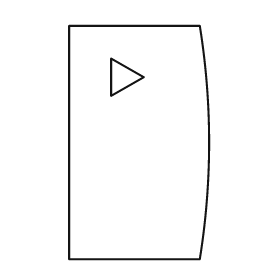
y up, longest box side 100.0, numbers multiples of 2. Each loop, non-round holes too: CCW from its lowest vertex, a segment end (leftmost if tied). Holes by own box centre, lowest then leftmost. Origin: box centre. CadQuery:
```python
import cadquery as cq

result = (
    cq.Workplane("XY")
    .moveTo(-30.0, -50.0)
    .lineTo(26.0, -50.0)
    .threePointArc((30.0, 0.0), (26.0, 50.0))
    .lineTo(-30.0, 50.0)
    .close()
    .moveTo(-12.0, 20.0)
    .lineTo(2.0, 28.0)
    .lineTo(-12.0, 36.0)
    .close()
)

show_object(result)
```